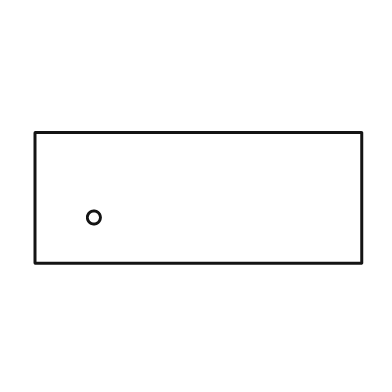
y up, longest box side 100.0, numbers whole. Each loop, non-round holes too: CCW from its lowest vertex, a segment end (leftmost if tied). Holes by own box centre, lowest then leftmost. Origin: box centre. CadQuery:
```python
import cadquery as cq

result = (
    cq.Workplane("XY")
    .moveTo(-50.0, -20.0)
    .lineTo(50.0, -20.0)
    .lineTo(50.0, 20.0)
    .lineTo(-50.0, 20.0)
    .close()
    .moveTo(-32.0, -6.0)
    .circle(2.0)
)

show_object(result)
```